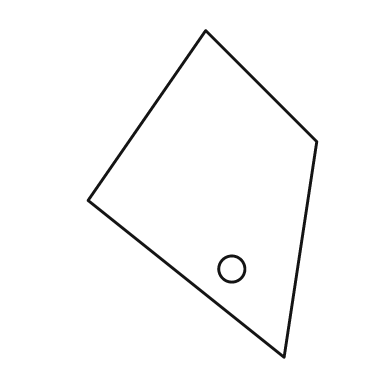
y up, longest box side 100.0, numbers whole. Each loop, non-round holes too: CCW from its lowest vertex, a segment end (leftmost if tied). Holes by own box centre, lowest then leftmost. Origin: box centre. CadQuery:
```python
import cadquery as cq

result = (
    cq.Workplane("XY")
    .moveTo(25.0, -50.0)
    .lineTo(35.0, 16.0)
    .lineTo(1.0, 50.0)
    .lineTo(-35.0, -2.0)
    .close()
    .moveTo(9.0, -23.0)
    .circle(4.0)
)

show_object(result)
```